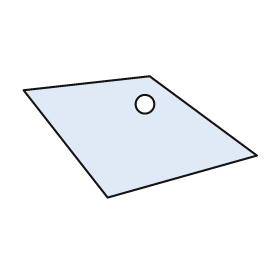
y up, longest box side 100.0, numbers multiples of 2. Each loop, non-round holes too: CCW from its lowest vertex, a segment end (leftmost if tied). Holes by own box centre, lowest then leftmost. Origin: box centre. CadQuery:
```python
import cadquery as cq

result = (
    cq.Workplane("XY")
    .moveTo(-14.0, -26.0)
    .lineTo(50.0, -8.0)
    .lineTo(4.0, 26.0)
    .lineTo(-50.0, 20.0)
    .close()
    .moveTo(2.0, 14.0)
    .circle(4.0)
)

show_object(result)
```